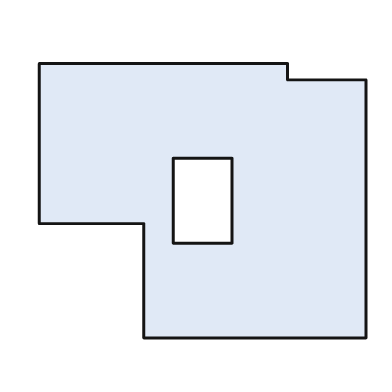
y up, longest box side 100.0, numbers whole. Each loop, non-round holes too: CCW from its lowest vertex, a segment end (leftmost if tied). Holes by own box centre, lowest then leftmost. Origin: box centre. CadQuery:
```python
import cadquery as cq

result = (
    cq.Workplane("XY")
    .moveTo(-18.0, -42.0)
    .lineTo(50.0, -42.0)
    .lineTo(50.0, 37.0)
    .lineTo(26.0, 37.0)
    .lineTo(26.0, 42.0)
    .lineTo(-50.0, 42.0)
    .lineTo(-50.0, -7.0)
    .lineTo(-18.0, -7.0)
    .close()
    .moveTo(-9.0, -13.0)
    .lineTo(9.0, -13.0)
    .lineTo(9.0, 13.0)
    .lineTo(-9.0, 13.0)
    .close()
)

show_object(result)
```